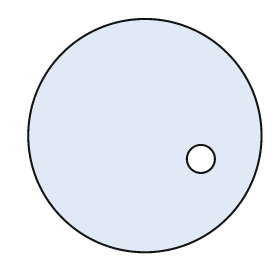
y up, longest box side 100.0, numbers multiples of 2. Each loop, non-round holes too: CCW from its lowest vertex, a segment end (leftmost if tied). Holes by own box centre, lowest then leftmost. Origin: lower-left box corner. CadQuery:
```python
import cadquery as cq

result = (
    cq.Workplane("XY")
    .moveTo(50.0, 50.0)
    .circle(50.0)
    .moveTo(74.0, 40.0)
    .circle(6.0)
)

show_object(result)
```